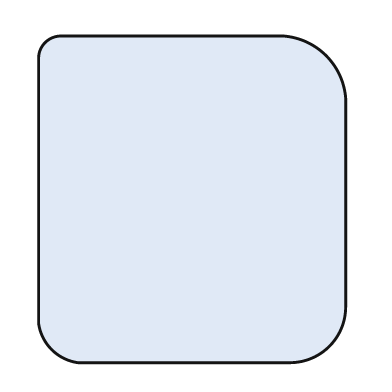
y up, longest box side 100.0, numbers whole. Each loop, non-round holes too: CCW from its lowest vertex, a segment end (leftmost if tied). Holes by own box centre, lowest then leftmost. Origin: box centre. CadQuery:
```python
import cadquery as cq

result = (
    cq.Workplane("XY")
    .moveTo(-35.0, -50.0)
    .lineTo(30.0, -50.0)
    .threePointArc((42.0, -45.0), (47.0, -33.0))
    .lineTo(47.0, 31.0)
    .threePointArc((41.0, 44.0), (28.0, 50.0))
    .lineTo(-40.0, 50.0)
    .threePointArc((-45.0, 48.0), (-47.0, 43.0))
    .lineTo(-47.0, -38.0)
    .threePointArc((-43.0, -46.0), (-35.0, -50.0))
    .close()
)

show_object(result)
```